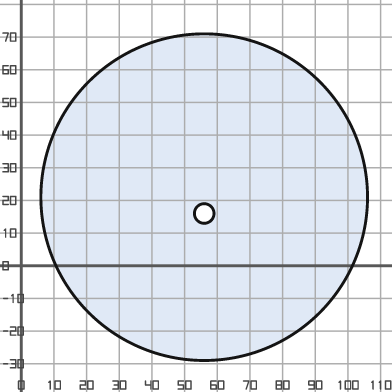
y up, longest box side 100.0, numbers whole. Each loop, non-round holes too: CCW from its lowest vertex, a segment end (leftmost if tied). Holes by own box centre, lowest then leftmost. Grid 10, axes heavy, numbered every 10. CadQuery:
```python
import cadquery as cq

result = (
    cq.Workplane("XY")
    .moveTo(56.0, 21.0)
    .circle(50.0)
    .moveTo(56.0, 16.0)
    .circle(3.0)
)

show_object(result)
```